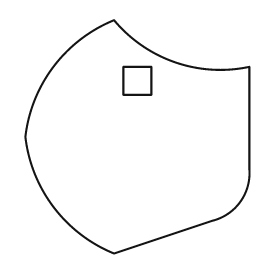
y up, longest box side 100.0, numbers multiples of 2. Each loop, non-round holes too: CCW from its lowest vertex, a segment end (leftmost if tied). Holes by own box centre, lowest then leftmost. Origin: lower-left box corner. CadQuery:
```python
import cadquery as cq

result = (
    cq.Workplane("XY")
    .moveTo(38.0, 0.0)
    .lineTo(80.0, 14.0)
    .threePointArc((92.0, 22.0), (96.0, 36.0))
    .lineTo(96.0, 80.0)
    .threePointArc((64.0, 82.0), (38.0, 100.0))
    .threePointArc((12.0, 80.0), (0.0, 50.0))
    .threePointArc((12.0, 20.0), (38.0, 0.0))
    .close()
    .moveTo(42.0, 68.0)
    .lineTo(54.0, 68.0)
    .lineTo(54.0, 80.0)
    .lineTo(42.0, 80.0)
    .close()
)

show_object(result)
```